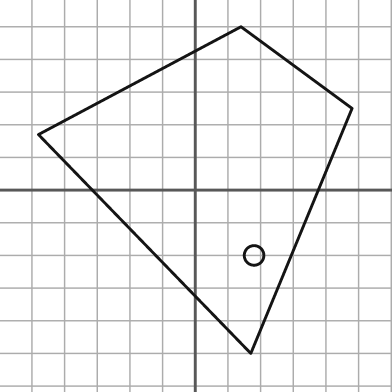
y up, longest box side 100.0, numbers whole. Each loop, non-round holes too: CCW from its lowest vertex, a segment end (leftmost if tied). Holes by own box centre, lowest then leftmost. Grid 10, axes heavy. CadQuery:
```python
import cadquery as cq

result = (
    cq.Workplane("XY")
    .moveTo(17.0, -50.0)
    .lineTo(48.0, 25.0)
    .lineTo(14.0, 50.0)
    .lineTo(-48.0, 17.0)
    .close()
    .moveTo(18.0, -20.0)
    .circle(3.0)
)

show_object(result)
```